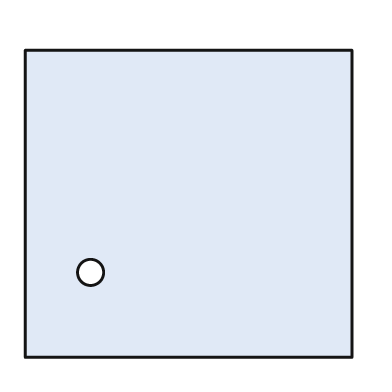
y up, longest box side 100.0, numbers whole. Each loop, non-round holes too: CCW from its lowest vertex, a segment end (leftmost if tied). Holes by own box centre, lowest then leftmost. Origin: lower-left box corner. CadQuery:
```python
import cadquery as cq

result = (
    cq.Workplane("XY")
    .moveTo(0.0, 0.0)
    .lineTo(100.0, 0.0)
    .lineTo(100.0, 94.0)
    .lineTo(0.0, 94.0)
    .close()
    .moveTo(20.0, 26.0)
    .circle(4.0)
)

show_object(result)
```